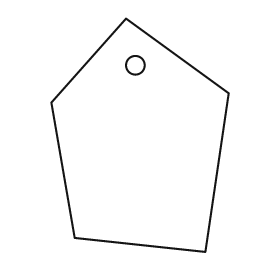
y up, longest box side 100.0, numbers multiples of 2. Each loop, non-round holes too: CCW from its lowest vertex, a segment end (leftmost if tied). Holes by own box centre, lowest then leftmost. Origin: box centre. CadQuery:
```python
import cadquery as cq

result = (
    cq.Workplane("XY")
    .moveTo(28.0, -50.0)
    .lineTo(38.0, 18.0)
    .lineTo(-6.0, 50.0)
    .lineTo(-38.0, 14.0)
    .lineTo(-28.0, -44.0)
    .close()
    .moveTo(-2.0, 30.0)
    .circle(4.0)
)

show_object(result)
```